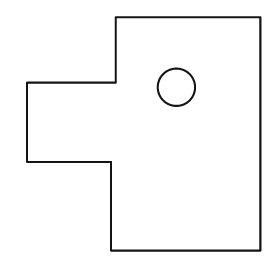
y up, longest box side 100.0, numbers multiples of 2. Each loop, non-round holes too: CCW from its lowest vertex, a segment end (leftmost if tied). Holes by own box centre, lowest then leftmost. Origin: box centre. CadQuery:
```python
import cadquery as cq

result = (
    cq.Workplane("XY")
    .moveTo(-14.0, -50.0)
    .lineTo(50.0, -50.0)
    .lineTo(50.0, 50.0)
    .lineTo(-12.0, 50.0)
    .lineTo(-12.0, 22.0)
    .lineTo(-50.0, 22.0)
    .lineTo(-50.0, -12.0)
    .lineTo(-14.0, -12.0)
    .close()
    .moveTo(14.0, 20.0)
    .circle(8.0)
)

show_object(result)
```